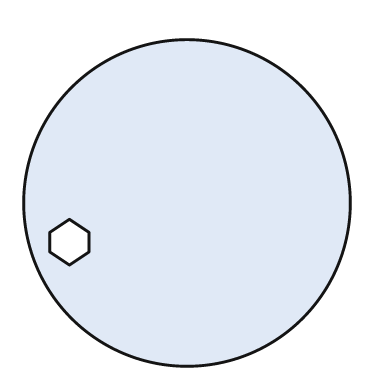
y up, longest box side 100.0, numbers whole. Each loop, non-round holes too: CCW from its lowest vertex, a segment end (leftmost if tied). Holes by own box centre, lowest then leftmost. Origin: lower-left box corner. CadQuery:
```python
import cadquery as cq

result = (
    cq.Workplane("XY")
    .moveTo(50.0, 50.0)
    .circle(50.0)
    .moveTo(14.0, 31.0)
    .lineTo(20.0, 35.0)
    .lineTo(20.0, 41.0)
    .lineTo(14.0, 45.0)
    .lineTo(8.0, 41.0)
    .lineTo(8.0, 35.0)
    .close()
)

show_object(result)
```